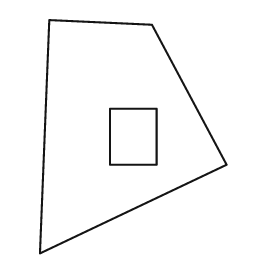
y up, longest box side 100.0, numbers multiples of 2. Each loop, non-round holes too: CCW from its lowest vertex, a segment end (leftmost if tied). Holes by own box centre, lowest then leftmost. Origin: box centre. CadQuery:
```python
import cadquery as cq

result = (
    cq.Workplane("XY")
    .moveTo(-40.0, -50.0)
    .lineTo(40.0, -12.0)
    .lineTo(8.0, 48.0)
    .lineTo(-36.0, 50.0)
    .close()
    .moveTo(-10.0, -12.0)
    .lineTo(10.0, -12.0)
    .lineTo(10.0, 12.0)
    .lineTo(-10.0, 12.0)
    .close()
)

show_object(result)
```